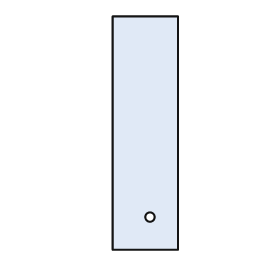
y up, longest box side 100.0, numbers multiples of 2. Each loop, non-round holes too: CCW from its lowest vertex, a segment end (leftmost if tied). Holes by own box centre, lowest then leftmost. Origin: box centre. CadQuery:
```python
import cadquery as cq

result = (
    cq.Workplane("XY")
    .moveTo(-14.0, -50.0)
    .lineTo(14.0, -50.0)
    .lineTo(14.0, 50.0)
    .lineTo(-14.0, 50.0)
    .close()
    .moveTo(2.0, -36.0)
    .circle(2.0)
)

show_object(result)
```